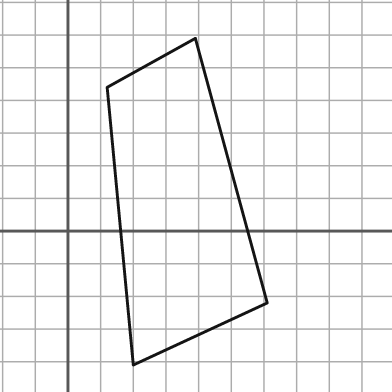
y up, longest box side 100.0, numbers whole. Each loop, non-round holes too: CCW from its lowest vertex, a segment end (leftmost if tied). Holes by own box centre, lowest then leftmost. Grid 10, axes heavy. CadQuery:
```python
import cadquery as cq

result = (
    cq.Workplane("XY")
    .moveTo(20.0, -41.0)
    .lineTo(61.0, -22.0)
    .lineTo(39.0, 59.0)
    .lineTo(12.0, 44.0)
    .close()
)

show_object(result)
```